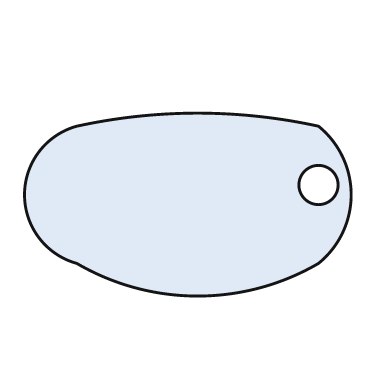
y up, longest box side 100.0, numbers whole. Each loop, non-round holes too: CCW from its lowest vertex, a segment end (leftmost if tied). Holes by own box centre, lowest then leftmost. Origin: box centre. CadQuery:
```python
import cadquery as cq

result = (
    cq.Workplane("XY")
    .moveTo(-34.0, -18.0)
    .threePointArc((3.0, -28.0), (40.0, -18.0))
    .threePointArc((50.0, 3.0), (40.0, 24.0))
    .threePointArc((3.0, 28.0), (-34.0, 24.0))
    .threePointArc((-50.0, 3.0), (-34.0, -18.0))
    .close()
    .moveTo(40.0, 6.0)
    .circle(6.0)
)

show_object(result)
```